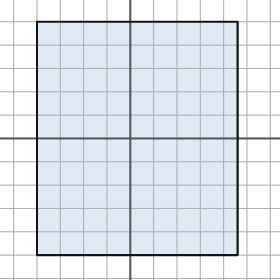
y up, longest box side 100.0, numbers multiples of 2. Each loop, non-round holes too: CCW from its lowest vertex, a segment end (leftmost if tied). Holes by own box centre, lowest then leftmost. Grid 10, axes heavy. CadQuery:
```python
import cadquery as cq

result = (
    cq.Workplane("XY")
    .moveTo(-40.0, -50.0)
    .lineTo(46.0, -50.0)
    .lineTo(46.0, 50.0)
    .lineTo(-40.0, 50.0)
    .close()
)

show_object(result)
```